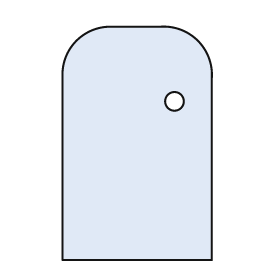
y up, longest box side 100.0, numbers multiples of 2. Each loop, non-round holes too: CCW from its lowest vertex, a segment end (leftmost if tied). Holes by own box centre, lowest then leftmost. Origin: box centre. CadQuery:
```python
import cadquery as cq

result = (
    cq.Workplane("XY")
    .moveTo(-32.0, -50.0)
    .lineTo(32.0, -50.0)
    .lineTo(32.0, 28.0)
    .threePointArc((26.0, 44.0), (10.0, 50.0))
    .lineTo(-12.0, 50.0)
    .threePointArc((-26.0, 44.0), (-32.0, 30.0))
    .close()
    .moveTo(16.0, 18.0)
    .circle(4.0)
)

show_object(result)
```